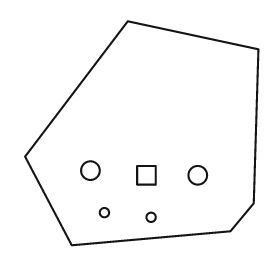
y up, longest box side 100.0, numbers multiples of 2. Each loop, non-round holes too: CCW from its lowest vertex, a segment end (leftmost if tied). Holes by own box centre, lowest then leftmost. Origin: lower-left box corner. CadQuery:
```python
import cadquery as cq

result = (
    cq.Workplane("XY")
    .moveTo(20.0, 0.0)
    .lineTo(88.0, 6.0)
    .lineTo(98.0, 18.0)
    .lineTo(100.0, 84.0)
    .lineTo(44.0, 96.0)
    .lineTo(0.0, 38.0)
    .close()
    .moveTo(54.0, 12.0)
    .circle(2.0)
    .moveTo(34.0, 14.0)
    .circle(2.0)
    .moveTo(48.0, 26.0)
    .lineTo(56.0, 26.0)
    .lineTo(56.0, 34.0)
    .lineTo(48.0, 34.0)
    .close()
    .moveTo(74.0, 30.0)
    .circle(4.0)
    .moveTo(28.0, 32.0)
    .circle(4.0)
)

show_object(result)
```